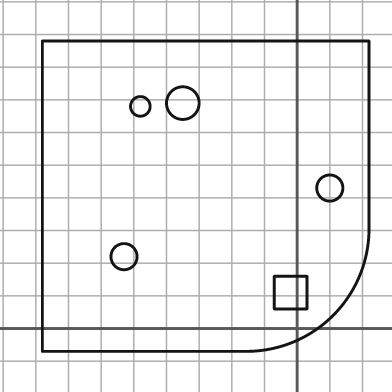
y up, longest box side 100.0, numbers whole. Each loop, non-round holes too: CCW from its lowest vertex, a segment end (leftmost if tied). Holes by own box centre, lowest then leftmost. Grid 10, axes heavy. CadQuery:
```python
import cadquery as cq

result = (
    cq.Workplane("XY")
    .moveTo(-78.0, -7.0)
    .lineTo(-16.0, -7.0)
    .threePointArc((11.0, 4.0), (22.0, 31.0))
    .lineTo(22.0, 88.0)
    .lineTo(-78.0, 88.0)
    .close()
    .moveTo(-7.0, 6.0)
    .lineTo(3.0, 6.0)
    .lineTo(3.0, 16.0)
    .lineTo(-7.0, 16.0)
    .close()
    .moveTo(-53.0, 22.0)
    .circle(4.0)
    .moveTo(10.0, 43.0)
    .circle(4.0)
    .moveTo(-48.0, 68.0)
    .circle(3.0)
    .moveTo(-35.0, 69.0)
    .circle(5.0)
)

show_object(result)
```